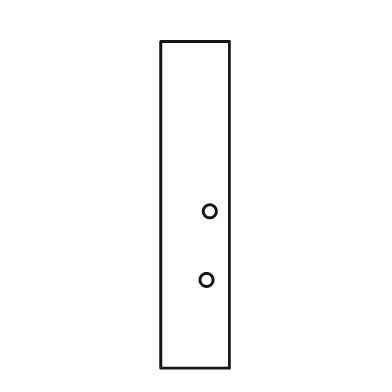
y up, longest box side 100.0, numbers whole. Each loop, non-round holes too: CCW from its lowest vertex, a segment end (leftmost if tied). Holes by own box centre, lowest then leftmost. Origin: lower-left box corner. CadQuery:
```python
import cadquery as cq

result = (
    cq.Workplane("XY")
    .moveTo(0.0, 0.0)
    .lineTo(21.0, 0.0)
    .lineTo(21.0, 100.0)
    .lineTo(0.0, 100.0)
    .close()
    .moveTo(14.0, 27.0)
    .circle(2.0)
    .moveTo(15.0, 48.0)
    .circle(2.0)
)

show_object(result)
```